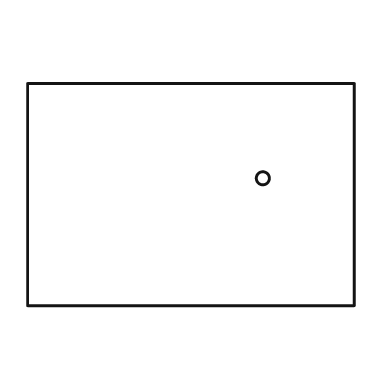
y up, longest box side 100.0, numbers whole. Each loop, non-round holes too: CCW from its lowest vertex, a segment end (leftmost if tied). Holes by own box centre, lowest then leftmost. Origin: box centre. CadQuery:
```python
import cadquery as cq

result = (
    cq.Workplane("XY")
    .moveTo(-50.0, -34.0)
    .lineTo(50.0, -34.0)
    .lineTo(50.0, 34.0)
    .lineTo(-50.0, 34.0)
    .close()
    .moveTo(22.0, 5.0)
    .circle(2.0)
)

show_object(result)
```